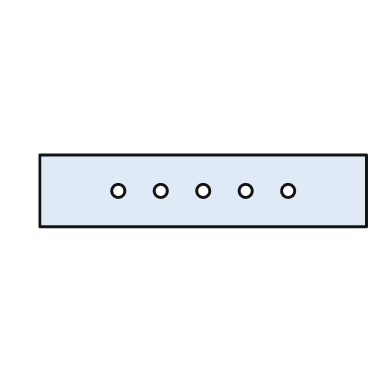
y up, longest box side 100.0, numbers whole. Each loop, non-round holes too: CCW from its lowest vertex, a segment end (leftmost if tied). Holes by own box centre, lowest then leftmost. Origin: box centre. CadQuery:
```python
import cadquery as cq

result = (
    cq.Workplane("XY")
    .moveTo(-50.0, -11.0)
    .lineTo(50.0, -11.0)
    .lineTo(50.0, 11.0)
    .lineTo(-50.0, 11.0)
    .close()
    .moveTo(-26.0, 0.0)
    .circle(2.0)
    .moveTo(-13.0, 0.0)
    .circle(2.0)
    .moveTo(0.0, 0.0)
    .circle(2.0)
    .moveTo(13.0, 0.0)
    .circle(2.0)
    .moveTo(26.0, 0.0)
    .circle(2.0)
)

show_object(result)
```